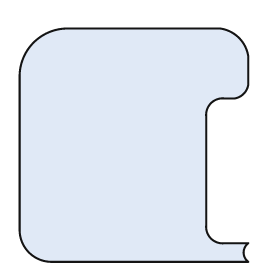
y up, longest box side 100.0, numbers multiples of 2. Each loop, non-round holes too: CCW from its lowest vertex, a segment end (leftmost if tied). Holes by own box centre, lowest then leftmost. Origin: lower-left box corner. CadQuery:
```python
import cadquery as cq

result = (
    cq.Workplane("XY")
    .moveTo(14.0, 0.0)
    .lineTo(98.0, 0.0)
    .threePointArc((96.0, 4.0), (98.0, 8.0))
    .lineTo(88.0, 8.0)
    .threePointArc((82.0, 10.0), (80.0, 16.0))
    .lineTo(80.0, 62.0)
    .threePointArc((82.0, 68.0), (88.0, 70.0))
    .lineTo(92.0, 70.0)
    .threePointArc((96.0, 72.0), (98.0, 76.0))
    .lineTo(98.0, 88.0)
    .threePointArc((94.0, 96.0), (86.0, 100.0))
    .lineTo(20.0, 100.0)
    .threePointArc((6.0, 94.0), (0.0, 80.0))
    .lineTo(0.0, 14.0)
    .threePointArc((4.0, 4.0), (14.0, 0.0))
    .close()
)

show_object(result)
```